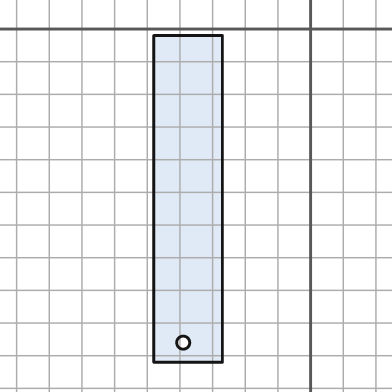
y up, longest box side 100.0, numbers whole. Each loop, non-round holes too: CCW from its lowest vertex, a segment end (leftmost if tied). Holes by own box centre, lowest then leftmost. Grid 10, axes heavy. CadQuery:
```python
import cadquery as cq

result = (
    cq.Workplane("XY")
    .moveTo(-48.0, -102.0)
    .lineTo(-27.0, -102.0)
    .lineTo(-27.0, -2.0)
    .lineTo(-48.0, -2.0)
    .close()
    .moveTo(-39.0, -96.0)
    .circle(2.0)
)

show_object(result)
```